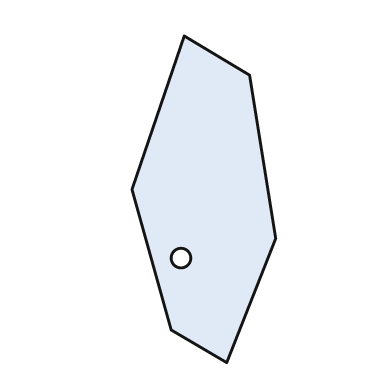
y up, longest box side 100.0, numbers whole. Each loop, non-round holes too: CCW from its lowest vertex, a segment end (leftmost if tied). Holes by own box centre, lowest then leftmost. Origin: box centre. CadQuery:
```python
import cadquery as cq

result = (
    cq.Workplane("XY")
    .moveTo(7.0, -50.0)
    .lineTo(22.0, -12.0)
    .lineTo(14.0, 38.0)
    .lineTo(-6.0, 50.0)
    .lineTo(-22.0, 3.0)
    .lineTo(-10.0, -40.0)
    .close()
    .moveTo(-7.0, -18.0)
    .circle(3.0)
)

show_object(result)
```